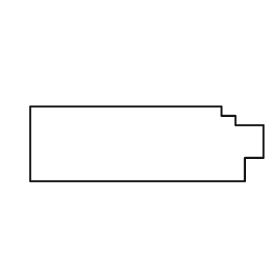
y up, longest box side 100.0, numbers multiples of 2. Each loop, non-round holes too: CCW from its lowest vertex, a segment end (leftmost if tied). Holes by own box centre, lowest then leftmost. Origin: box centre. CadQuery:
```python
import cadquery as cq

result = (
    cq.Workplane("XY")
    .moveTo(-50.0, -16.0)
    .lineTo(42.0, -16.0)
    .lineTo(42.0, -6.0)
    .lineTo(50.0, -6.0)
    .lineTo(50.0, 8.0)
    .lineTo(38.0, 8.0)
    .lineTo(38.0, 12.0)
    .lineTo(32.0, 12.0)
    .lineTo(32.0, 16.0)
    .lineTo(-50.0, 16.0)
    .close()
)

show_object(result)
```